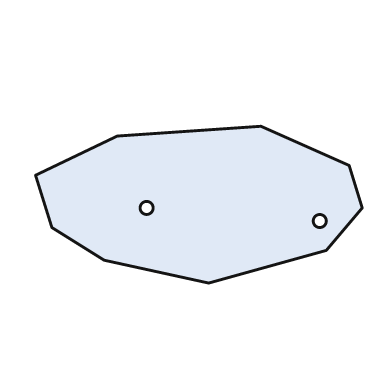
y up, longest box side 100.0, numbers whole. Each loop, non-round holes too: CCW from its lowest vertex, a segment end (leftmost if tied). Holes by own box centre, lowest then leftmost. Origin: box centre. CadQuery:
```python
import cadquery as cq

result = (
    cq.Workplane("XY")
    .moveTo(3.0, -24.0)
    .lineTo(39.0, -14.0)
    .lineTo(50.0, -1.0)
    .lineTo(46.0, 12.0)
    .lineTo(19.0, 24.0)
    .lineTo(-25.0, 21.0)
    .lineTo(-50.0, 9.0)
    .lineTo(-45.0, -7.0)
    .lineTo(-29.0, -17.0)
    .close()
    .moveTo(37.0, -5.0)
    .circle(2.0)
    .moveTo(-16.0, -1.0)
    .circle(2.0)
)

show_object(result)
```